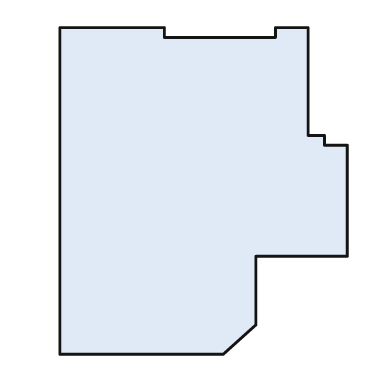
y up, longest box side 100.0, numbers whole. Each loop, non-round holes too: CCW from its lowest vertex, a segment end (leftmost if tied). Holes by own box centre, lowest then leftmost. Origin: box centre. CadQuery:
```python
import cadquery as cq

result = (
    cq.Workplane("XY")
    .moveTo(-44.0, -50.0)
    .lineTo(6.0, -50.0)
    .lineTo(16.0, -41.0)
    .lineTo(16.0, -20.0)
    .lineTo(44.0, -20.0)
    .lineTo(44.0, 14.0)
    .lineTo(37.0, 14.0)
    .lineTo(37.0, 17.0)
    .lineTo(32.0, 17.0)
    .lineTo(32.0, 50.0)
    .lineTo(22.0, 50.0)
    .lineTo(22.0, 47.0)
    .lineTo(-12.0, 47.0)
    .lineTo(-12.0, 50.0)
    .lineTo(-44.0, 50.0)
    .close()
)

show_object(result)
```